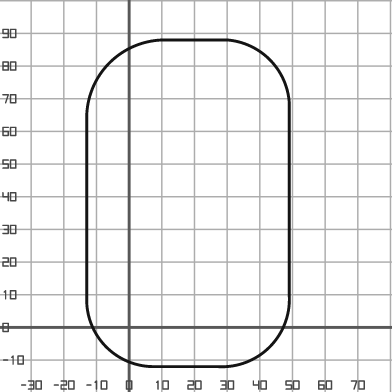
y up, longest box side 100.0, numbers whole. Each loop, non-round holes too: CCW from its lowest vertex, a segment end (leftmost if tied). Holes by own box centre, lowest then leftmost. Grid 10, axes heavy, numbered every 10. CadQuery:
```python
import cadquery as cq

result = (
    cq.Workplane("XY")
    .moveTo(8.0, -12.0)
    .lineTo(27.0, -12.0)
    .threePointArc((43.0, -6.0), (49.0, 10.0))
    .lineTo(49.0, 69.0)
    .threePointArc((43.0, 82.0), (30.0, 88.0))
    .lineTo(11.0, 88.0)
    .threePointArc((-6.0, 81.0), (-13.0, 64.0))
    .lineTo(-13.0, 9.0)
    .threePointArc((-7.0, -6.0), (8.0, -12.0))
    .close()
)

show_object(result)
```